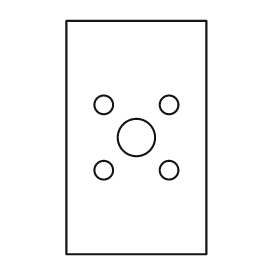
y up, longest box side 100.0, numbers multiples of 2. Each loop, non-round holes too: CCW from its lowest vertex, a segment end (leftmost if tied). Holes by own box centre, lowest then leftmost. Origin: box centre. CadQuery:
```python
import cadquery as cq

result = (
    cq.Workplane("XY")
    .moveTo(-30.0, -50.0)
    .lineTo(30.0, -50.0)
    .lineTo(30.0, 50.0)
    .lineTo(-30.0, 50.0)
    .close()
    .moveTo(-14.0, -14.0)
    .circle(4.0)
    .moveTo(14.0, -14.0)
    .circle(4.0)
    .moveTo(0.0, 0.0)
    .circle(8.0)
    .moveTo(-14.0, 14.0)
    .circle(4.0)
    .moveTo(14.0, 14.0)
    .circle(4.0)
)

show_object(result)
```